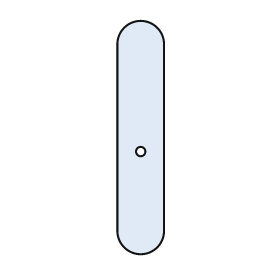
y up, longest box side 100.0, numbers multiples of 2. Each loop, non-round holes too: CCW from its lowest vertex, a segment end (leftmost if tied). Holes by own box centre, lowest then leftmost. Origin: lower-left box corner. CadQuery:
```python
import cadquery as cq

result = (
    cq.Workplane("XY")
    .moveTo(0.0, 10.0)
    .threePointArc((10.0, 0.0), (20.0, 10.0))
    .lineTo(20.0, 90.0)
    .threePointArc((10.0, 100.0), (0.0, 90.0))
    .close()
    .moveTo(10.0, 44.0)
    .circle(2.0)
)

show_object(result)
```